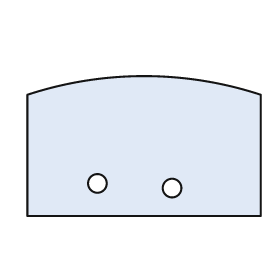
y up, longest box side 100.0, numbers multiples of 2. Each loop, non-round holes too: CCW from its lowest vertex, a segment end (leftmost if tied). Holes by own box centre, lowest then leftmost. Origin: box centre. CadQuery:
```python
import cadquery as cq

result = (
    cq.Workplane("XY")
    .moveTo(-50.0, -30.0)
    .lineTo(50.0, -30.0)
    .lineTo(50.0, 22.0)
    .threePointArc((0.0, 30.0), (-50.0, 22.0))
    .close()
    .moveTo(12.0, -18.0)
    .circle(4.0)
    .moveTo(-20.0, -16.0)
    .circle(4.0)
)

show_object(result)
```